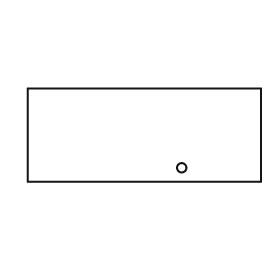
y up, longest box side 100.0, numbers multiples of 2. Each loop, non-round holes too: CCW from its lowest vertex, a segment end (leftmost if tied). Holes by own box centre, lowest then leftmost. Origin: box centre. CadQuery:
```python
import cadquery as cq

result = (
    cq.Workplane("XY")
    .moveTo(-50.0, -20.0)
    .lineTo(50.0, -20.0)
    .lineTo(50.0, 20.0)
    .lineTo(-50.0, 20.0)
    .close()
    .moveTo(16.0, -14.0)
    .circle(2.0)
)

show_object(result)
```